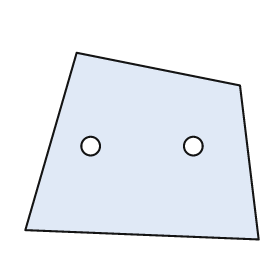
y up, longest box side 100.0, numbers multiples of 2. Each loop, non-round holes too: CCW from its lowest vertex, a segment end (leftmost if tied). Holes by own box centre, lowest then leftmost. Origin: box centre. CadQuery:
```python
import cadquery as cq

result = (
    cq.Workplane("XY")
    .moveTo(50.0, -40.0)
    .lineTo(42.0, 26.0)
    .lineTo(-28.0, 40.0)
    .lineTo(-50.0, -36.0)
    .close()
    .moveTo(-22.0, 0.0)
    .circle(4.0)
    .moveTo(22.0, 0.0)
    .circle(4.0)
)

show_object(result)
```